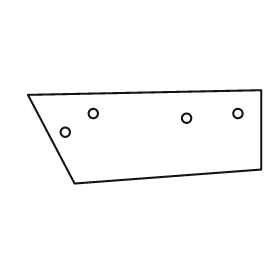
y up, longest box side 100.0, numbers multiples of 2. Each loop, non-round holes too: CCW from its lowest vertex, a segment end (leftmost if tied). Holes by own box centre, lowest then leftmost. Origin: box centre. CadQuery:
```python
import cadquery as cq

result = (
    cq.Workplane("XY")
    .moveTo(-30.0, -20.0)
    .lineTo(50.0, -14.0)
    .lineTo(50.0, 20.0)
    .lineTo(-50.0, 18.0)
    .close()
    .moveTo(-34.0, 2.0)
    .circle(2.0)
    .moveTo(18.0, 8.0)
    .circle(2.0)
    .moveTo(-22.0, 10.0)
    .circle(2.0)
    .moveTo(40.0, 10.0)
    .circle(2.0)
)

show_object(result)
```